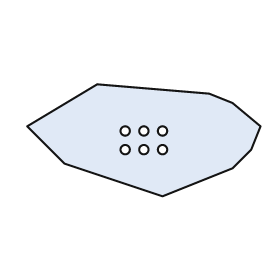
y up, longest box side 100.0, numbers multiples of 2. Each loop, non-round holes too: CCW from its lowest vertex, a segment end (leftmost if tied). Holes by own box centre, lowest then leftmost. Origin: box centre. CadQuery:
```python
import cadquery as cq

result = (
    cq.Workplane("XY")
    .moveTo(8.0, -24.0)
    .lineTo(38.0, -12.0)
    .lineTo(46.0, -4.0)
    .lineTo(50.0, 6.0)
    .lineTo(38.0, 16.0)
    .lineTo(28.0, 20.0)
    .lineTo(-20.0, 24.0)
    .lineTo(-50.0, 6.0)
    .lineTo(-34.0, -10.0)
    .close()
    .moveTo(-8.0, -4.0)
    .circle(2.0)
    .moveTo(0.0, -4.0)
    .circle(2.0)
    .moveTo(8.0, -4.0)
    .circle(2.0)
    .moveTo(-8.0, 4.0)
    .circle(2.0)
    .moveTo(0.0, 4.0)
    .circle(2.0)
    .moveTo(8.0, 4.0)
    .circle(2.0)
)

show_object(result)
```